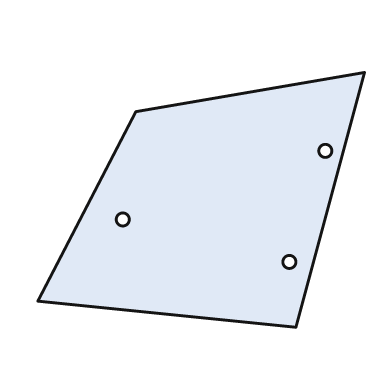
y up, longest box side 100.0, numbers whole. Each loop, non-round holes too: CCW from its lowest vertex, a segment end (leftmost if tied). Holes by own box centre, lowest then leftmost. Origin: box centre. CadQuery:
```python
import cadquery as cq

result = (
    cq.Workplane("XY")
    .moveTo(29.0, -39.0)
    .lineTo(50.0, 39.0)
    .lineTo(-20.0, 27.0)
    .lineTo(-50.0, -31.0)
    .close()
    .moveTo(27.0, -19.0)
    .circle(2.0)
    .moveTo(-24.0, -6.0)
    .circle(2.0)
    .moveTo(38.0, 15.0)
    .circle(2.0)
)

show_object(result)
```